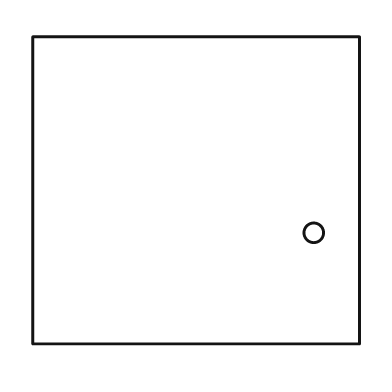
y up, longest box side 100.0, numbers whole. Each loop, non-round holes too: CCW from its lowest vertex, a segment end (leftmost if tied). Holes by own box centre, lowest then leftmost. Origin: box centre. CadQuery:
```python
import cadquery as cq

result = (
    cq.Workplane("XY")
    .moveTo(-50.0, -47.0)
    .lineTo(50.0, -47.0)
    .lineTo(50.0, 47.0)
    .lineTo(-50.0, 47.0)
    .close()
    .moveTo(36.0, -13.0)
    .circle(3.0)
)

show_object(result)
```